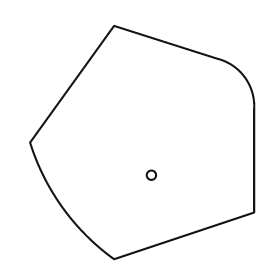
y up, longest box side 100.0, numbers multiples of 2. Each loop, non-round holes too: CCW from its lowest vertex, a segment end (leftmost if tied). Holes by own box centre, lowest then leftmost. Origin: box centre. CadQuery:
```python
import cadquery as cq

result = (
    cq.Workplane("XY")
    .moveTo(-12.0, -50.0)
    .lineTo(48.0, -30.0)
    .lineTo(48.0, 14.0)
    .threePointArc((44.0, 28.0), (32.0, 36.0))
    .lineTo(-12.0, 50.0)
    .lineTo(-48.0, 0.0)
    .threePointArc((-34.0, -28.0), (-12.0, -50.0))
    .close()
    .moveTo(4.0, -14.0)
    .circle(2.0)
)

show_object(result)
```